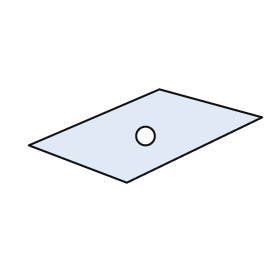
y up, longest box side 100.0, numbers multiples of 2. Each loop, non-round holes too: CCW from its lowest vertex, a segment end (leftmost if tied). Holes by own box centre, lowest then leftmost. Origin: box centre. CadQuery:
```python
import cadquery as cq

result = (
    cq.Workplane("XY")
    .moveTo(-8.0, -20.0)
    .lineTo(50.0, 8.0)
    .lineTo(6.0, 20.0)
    .lineTo(-50.0, -4.0)
    .close()
    .moveTo(0.0, 0.0)
    .circle(4.0)
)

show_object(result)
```